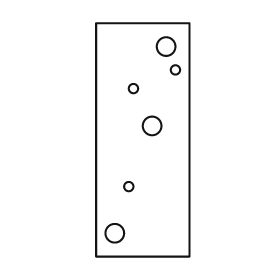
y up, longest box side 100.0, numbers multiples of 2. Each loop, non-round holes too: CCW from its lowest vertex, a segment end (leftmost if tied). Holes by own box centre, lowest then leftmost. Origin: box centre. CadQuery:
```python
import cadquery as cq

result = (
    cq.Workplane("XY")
    .moveTo(-20.0, -50.0)
    .lineTo(20.0, -50.0)
    .lineTo(20.0, 50.0)
    .lineTo(-20.0, 50.0)
    .close()
    .moveTo(-12.0, -40.0)
    .circle(4.0)
    .moveTo(-6.0, -20.0)
    .circle(2.0)
    .moveTo(4.0, 6.0)
    .circle(4.0)
    .moveTo(-4.0, 22.0)
    .circle(2.0)
    .moveTo(14.0, 30.0)
    .circle(2.0)
    .moveTo(10.0, 40.0)
    .circle(4.0)
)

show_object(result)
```